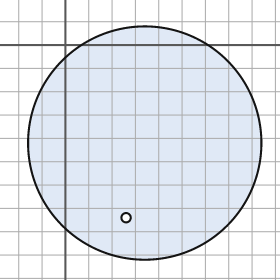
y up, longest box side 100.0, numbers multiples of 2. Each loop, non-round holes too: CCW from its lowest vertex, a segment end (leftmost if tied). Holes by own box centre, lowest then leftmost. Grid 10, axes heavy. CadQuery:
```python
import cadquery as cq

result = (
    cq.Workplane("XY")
    .moveTo(34.0, -42.0)
    .circle(50.0)
    .moveTo(26.0, -74.0)
    .circle(2.0)
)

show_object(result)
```